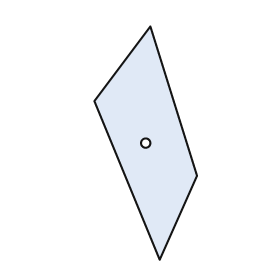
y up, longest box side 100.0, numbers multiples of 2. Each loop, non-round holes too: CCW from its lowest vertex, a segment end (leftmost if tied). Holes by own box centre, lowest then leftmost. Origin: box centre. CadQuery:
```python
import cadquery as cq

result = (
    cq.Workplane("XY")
    .moveTo(6.0, -50.0)
    .lineTo(22.0, -14.0)
    .lineTo(2.0, 50.0)
    .lineTo(-22.0, 18.0)
    .close()
    .moveTo(0.0, 0.0)
    .circle(2.0)
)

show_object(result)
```